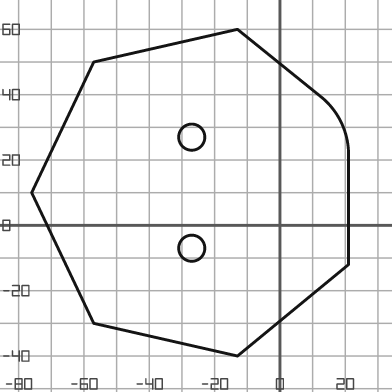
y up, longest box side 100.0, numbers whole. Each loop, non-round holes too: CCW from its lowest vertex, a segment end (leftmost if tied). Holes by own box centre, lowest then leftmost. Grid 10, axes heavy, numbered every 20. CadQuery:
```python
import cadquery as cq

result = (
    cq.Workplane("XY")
    .moveTo(-13.0, -40.0)
    .lineTo(21.0, -12.0)
    .lineTo(21.0, 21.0)
    .threePointArc((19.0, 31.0), (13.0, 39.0))
    .lineTo(-13.0, 60.0)
    .lineTo(-57.0, 50.0)
    .lineTo(-76.0, 10.0)
    .lineTo(-57.0, -30.0)
    .close()
    .moveTo(-27.0, -7.0)
    .circle(4.0)
    .moveTo(-27.0, 27.0)
    .circle(4.0)
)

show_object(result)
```